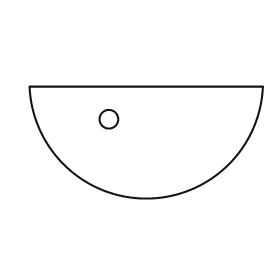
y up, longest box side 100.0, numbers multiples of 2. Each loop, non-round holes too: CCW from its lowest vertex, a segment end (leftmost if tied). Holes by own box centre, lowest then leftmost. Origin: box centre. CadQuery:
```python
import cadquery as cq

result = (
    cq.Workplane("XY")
    .moveTo(-50.0, 24.0)
    .threePointArc((0.0, -24.0), (50.0, 24.0))
    .close()
    .moveTo(-16.0, 10.0)
    .circle(4.0)
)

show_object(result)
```